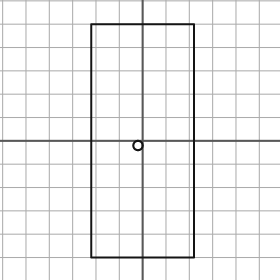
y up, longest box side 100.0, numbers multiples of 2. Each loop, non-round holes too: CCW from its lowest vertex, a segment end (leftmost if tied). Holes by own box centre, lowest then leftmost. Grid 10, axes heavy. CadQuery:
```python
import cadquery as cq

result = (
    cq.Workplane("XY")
    .moveTo(-22.0, -50.0)
    .lineTo(22.0, -50.0)
    .lineTo(22.0, 50.0)
    .lineTo(-22.0, 50.0)
    .close()
    .moveTo(-2.0, -2.0)
    .circle(2.0)
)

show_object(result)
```